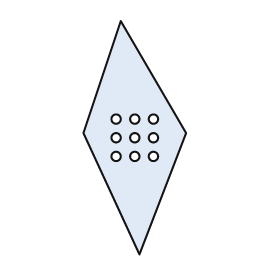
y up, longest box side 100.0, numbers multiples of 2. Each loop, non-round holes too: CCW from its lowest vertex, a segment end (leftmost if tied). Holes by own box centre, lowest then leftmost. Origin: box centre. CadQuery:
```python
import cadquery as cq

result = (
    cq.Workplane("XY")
    .moveTo(2.0, -50.0)
    .lineTo(22.0, 2.0)
    .lineTo(-6.0, 50.0)
    .lineTo(-22.0, 2.0)
    .close()
    .moveTo(-8.0, -8.0)
    .circle(2.0)
    .moveTo(0.0, -8.0)
    .circle(2.0)
    .moveTo(8.0, -8.0)
    .circle(2.0)
    .moveTo(-8.0, 0.0)
    .circle(2.0)
    .moveTo(0.0, 0.0)
    .circle(2.0)
    .moveTo(8.0, 0.0)
    .circle(2.0)
    .moveTo(-8.0, 8.0)
    .circle(2.0)
    .moveTo(0.0, 8.0)
    .circle(2.0)
    .moveTo(8.0, 8.0)
    .circle(2.0)
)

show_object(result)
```